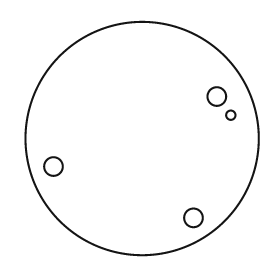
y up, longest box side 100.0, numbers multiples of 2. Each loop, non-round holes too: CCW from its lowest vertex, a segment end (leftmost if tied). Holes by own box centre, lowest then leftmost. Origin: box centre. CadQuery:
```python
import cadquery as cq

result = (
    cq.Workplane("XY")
    .moveTo(0.0, 0.0)
    .circle(50.0)
    .moveTo(22.0, -34.0)
    .circle(4.0)
    .moveTo(-38.0, -12.0)
    .circle(4.0)
    .moveTo(38.0, 10.0)
    .circle(2.0)
    .moveTo(32.0, 18.0)
    .circle(4.0)
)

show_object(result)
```